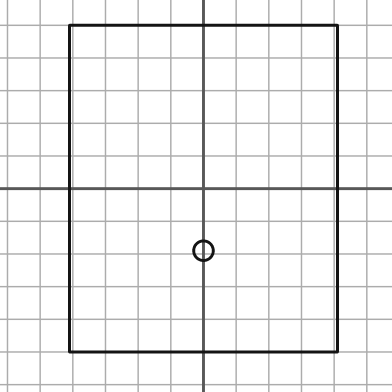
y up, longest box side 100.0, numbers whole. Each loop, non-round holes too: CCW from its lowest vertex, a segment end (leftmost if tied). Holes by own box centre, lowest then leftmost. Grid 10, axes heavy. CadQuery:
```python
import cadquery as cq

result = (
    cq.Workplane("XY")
    .moveTo(-41.0, -50.0)
    .lineTo(41.0, -50.0)
    .lineTo(41.0, 50.0)
    .lineTo(-41.0, 50.0)
    .close()
    .moveTo(0.0, -19.0)
    .circle(3.0)
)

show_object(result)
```